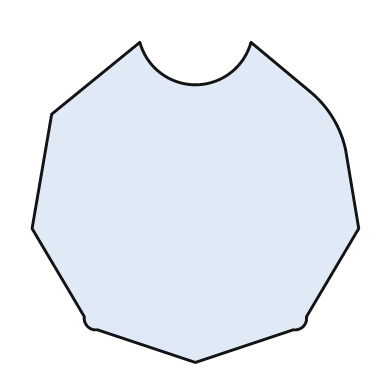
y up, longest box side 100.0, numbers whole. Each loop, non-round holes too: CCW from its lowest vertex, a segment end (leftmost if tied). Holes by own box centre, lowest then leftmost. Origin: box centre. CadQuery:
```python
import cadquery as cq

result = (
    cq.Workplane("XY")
    .moveTo(0.0, -49.0)
    .lineTo(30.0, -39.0)
    .threePointArc((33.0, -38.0), (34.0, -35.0))
    .lineTo(50.0, -8.0)
    .lineTo(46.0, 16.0)
    .threePointArc((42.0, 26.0), (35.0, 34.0))
    .lineTo(17.0, 49.0)
    .threePointArc((0.0, 36.0), (-17.0, 49.0))
    .lineTo(-44.0, 27.0)
    .lineTo(-50.0, -8.0)
    .lineTo(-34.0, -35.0)
    .threePointArc((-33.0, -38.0), (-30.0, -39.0))
    .close()
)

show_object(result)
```